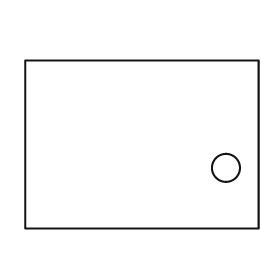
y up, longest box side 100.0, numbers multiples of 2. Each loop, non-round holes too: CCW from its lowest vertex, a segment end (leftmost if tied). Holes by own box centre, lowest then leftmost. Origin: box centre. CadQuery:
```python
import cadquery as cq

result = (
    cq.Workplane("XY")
    .moveTo(-50.0, -36.0)
    .lineTo(50.0, -36.0)
    .lineTo(50.0, 36.0)
    .lineTo(-50.0, 36.0)
    .close()
    .moveTo(36.0, -10.0)
    .circle(6.0)
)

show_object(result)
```